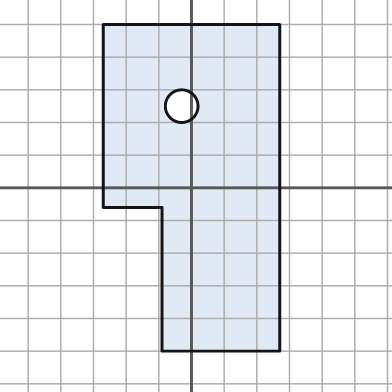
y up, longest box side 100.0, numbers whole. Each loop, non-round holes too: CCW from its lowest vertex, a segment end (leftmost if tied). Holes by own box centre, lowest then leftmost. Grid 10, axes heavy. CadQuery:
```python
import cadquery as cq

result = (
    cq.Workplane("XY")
    .moveTo(-9.0, -50.0)
    .lineTo(27.0, -50.0)
    .lineTo(27.0, 50.0)
    .lineTo(-27.0, 50.0)
    .lineTo(-27.0, -6.0)
    .lineTo(-9.0, -6.0)
    .close()
    .moveTo(-3.0, 25.0)
    .circle(5.0)
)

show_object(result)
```